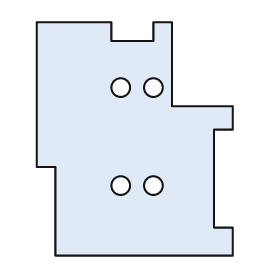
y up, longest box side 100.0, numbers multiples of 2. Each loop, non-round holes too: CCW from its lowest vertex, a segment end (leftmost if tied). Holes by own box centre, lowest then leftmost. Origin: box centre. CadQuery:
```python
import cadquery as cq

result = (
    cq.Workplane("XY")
    .moveTo(-34.0, -50.0)
    .lineTo(42.0, -50.0)
    .lineTo(42.0, -38.0)
    .lineTo(34.0, -38.0)
    .lineTo(34.0, 4.0)
    .lineTo(42.0, 4.0)
    .lineTo(42.0, 14.0)
    .lineTo(16.0, 14.0)
    .lineTo(16.0, 50.0)
    .lineTo(8.0, 50.0)
    .lineTo(8.0, 42.0)
    .lineTo(-10.0, 42.0)
    .lineTo(-10.0, 50.0)
    .lineTo(-42.0, 50.0)
    .lineTo(-42.0, -12.0)
    .lineTo(-34.0, -12.0)
    .close()
    .moveTo(-6.0, -20.0)
    .circle(4.0)
    .moveTo(8.0, -20.0)
    .circle(4.0)
    .moveTo(-6.0, 22.0)
    .circle(4.0)
    .moveTo(8.0, 22.0)
    .circle(4.0)
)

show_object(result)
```